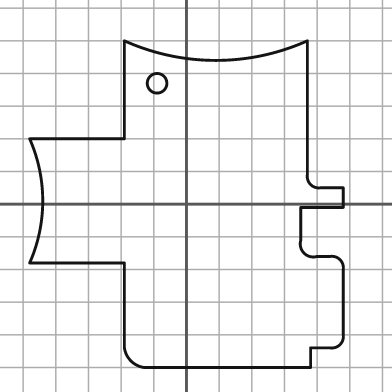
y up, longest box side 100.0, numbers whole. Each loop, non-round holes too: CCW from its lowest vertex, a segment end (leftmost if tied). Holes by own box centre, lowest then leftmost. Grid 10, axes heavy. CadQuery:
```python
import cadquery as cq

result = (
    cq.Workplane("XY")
    .moveTo(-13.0, -50.0)
    .lineTo(38.0, -50.0)
    .lineTo(38.0, -44.0)
    .lineTo(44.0, -44.0)
    .threePointArc((47.0, -43.0), (48.0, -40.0))
    .lineTo(48.0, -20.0)
    .threePointArc((47.0, -17.0), (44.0, -16.0))
    .lineTo(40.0, -16.0)
    .threePointArc((36.0, -15.0), (35.0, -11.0))
    .lineTo(35.0, -1.0)
    .lineTo(48.0, -1.0)
    .lineTo(48.0, 5.0)
    .lineTo(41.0, 5.0)
    .threePointArc((38.0, 6.0), (37.0, 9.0))
    .lineTo(37.0, 50.0)
    .threePointArc((9.0, 44.0), (-19.0, 50.0))
    .lineTo(-19.0, 20.0)
    .lineTo(-48.0, 20.0)
    .threePointArc((-44.0, 1.0), (-48.0, -18.0))
    .lineTo(-19.0, -18.0)
    .lineTo(-19.0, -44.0)
    .threePointArc((-17.0, -48.0), (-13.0, -50.0))
    .close()
    .moveTo(-9.0, 37.0)
    .circle(3.0)
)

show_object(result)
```